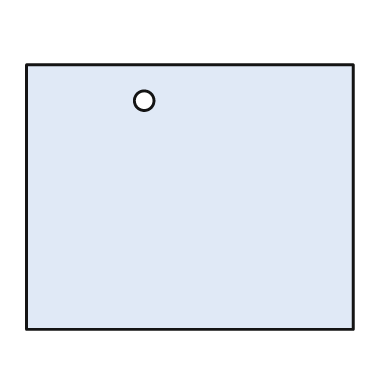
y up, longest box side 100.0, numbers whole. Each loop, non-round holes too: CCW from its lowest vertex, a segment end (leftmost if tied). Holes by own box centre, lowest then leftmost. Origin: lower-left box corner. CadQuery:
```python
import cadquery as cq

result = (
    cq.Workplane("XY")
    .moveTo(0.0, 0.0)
    .lineTo(100.0, 0.0)
    .lineTo(100.0, 81.0)
    .lineTo(0.0, 81.0)
    .close()
    .moveTo(36.0, 70.0)
    .circle(3.0)
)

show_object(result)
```